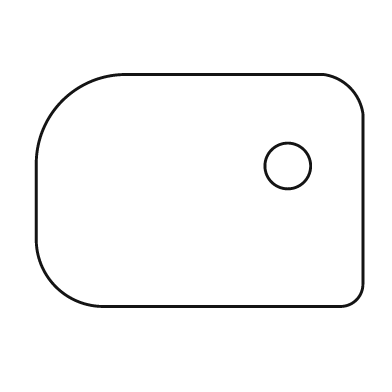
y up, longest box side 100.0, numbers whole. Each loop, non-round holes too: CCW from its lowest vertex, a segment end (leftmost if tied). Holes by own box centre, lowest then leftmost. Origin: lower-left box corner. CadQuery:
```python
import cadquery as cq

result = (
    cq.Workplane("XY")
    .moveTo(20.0, 0.0)
    .lineTo(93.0, 0.0)
    .threePointArc((98.0, 2.0), (100.0, 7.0))
    .lineTo(100.0, 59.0)
    .threePointArc((96.0, 67.0), (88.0, 71.0))
    .lineTo(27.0, 71.0)
    .threePointArc((8.0, 63.0), (0.0, 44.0))
    .lineTo(0.0, 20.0)
    .threePointArc((6.0, 6.0), (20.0, 0.0))
    .close()
    .moveTo(77.0, 43.0)
    .circle(7.0)
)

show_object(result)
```